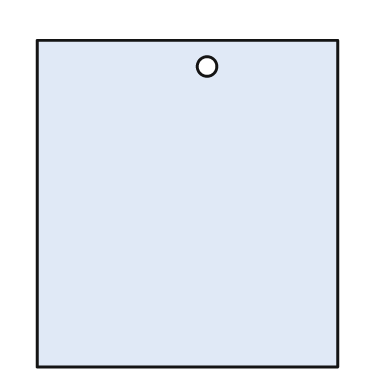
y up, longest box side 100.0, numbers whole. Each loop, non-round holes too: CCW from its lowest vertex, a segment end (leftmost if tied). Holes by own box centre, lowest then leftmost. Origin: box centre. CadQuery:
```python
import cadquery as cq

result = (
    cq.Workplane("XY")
    .moveTo(-46.0, -50.0)
    .lineTo(46.0, -50.0)
    .lineTo(46.0, 50.0)
    .lineTo(-46.0, 50.0)
    .close()
    .moveTo(6.0, 42.0)
    .circle(3.0)
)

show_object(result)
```